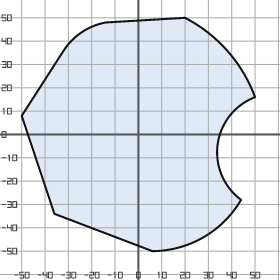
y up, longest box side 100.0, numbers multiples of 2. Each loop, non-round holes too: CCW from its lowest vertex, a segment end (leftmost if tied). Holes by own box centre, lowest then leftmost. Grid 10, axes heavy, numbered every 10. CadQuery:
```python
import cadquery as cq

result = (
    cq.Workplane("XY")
    .moveTo(6.0, -50.0)
    .threePointArc((28.0, -44.0), (44.0, -28.0))
    .threePointArc((34.0, -4.0), (50.0, 16.0))
    .threePointArc((38.0, 36.0), (20.0, 50.0))
    .lineTo(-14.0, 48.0)
    .threePointArc((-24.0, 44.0), (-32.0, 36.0))
    .lineTo(-50.0, 8.0)
    .lineTo(-36.0, -34.0)
    .close()
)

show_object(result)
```